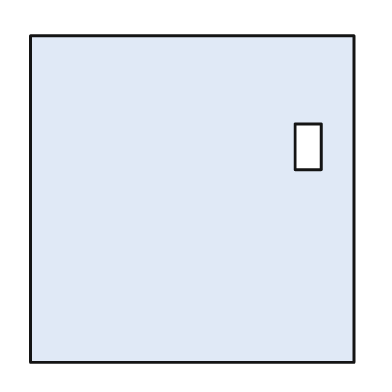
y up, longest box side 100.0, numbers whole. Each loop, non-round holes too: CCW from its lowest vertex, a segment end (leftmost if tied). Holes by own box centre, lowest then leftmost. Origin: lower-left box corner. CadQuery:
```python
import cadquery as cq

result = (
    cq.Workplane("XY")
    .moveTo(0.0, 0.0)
    .lineTo(99.0, 0.0)
    .lineTo(99.0, 100.0)
    .lineTo(0.0, 100.0)
    .close()
    .moveTo(81.0, 59.0)
    .lineTo(89.0, 59.0)
    .lineTo(89.0, 73.0)
    .lineTo(81.0, 73.0)
    .close()
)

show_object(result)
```